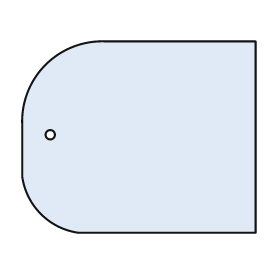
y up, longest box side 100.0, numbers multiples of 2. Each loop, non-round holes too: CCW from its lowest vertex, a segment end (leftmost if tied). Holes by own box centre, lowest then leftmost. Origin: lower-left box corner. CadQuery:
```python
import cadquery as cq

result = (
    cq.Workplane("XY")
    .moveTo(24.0, 0.0)
    .lineTo(100.0, 0.0)
    .lineTo(100.0, 82.0)
    .lineTo(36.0, 82.0)
    .threePointArc((10.0, 72.0), (0.0, 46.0))
    .lineTo(0.0, 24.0)
    .threePointArc((8.0, 8.0), (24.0, 0.0))
    .close()
    .moveTo(12.0, 42.0)
    .circle(2.0)
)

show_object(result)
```